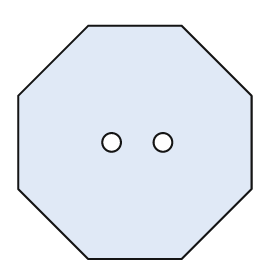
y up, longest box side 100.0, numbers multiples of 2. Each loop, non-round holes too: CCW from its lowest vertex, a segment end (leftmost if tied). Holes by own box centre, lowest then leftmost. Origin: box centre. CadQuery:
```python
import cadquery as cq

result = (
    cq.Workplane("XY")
    .moveTo(-20.0, -50.0)
    .lineTo(20.0, -50.0)
    .lineTo(50.0, -20.0)
    .lineTo(50.0, 20.0)
    .lineTo(20.0, 50.0)
    .lineTo(-20.0, 50.0)
    .lineTo(-50.0, 20.0)
    .lineTo(-50.0, -20.0)
    .close()
    .moveTo(-10.0, 0.0)
    .circle(4.0)
    .moveTo(12.0, 0.0)
    .circle(4.0)
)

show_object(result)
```